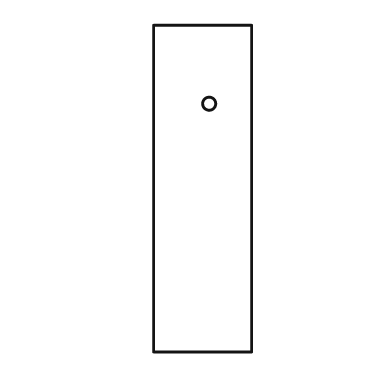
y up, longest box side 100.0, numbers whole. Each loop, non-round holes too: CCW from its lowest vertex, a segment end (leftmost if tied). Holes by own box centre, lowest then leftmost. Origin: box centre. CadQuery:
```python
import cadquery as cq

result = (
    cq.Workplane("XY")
    .moveTo(-15.0, -50.0)
    .lineTo(15.0, -50.0)
    .lineTo(15.0, 50.0)
    .lineTo(-15.0, 50.0)
    .close()
    .moveTo(2.0, 26.0)
    .circle(2.0)
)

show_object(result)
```